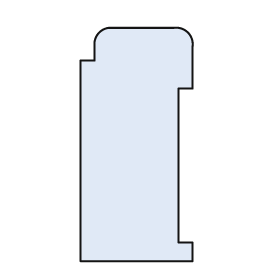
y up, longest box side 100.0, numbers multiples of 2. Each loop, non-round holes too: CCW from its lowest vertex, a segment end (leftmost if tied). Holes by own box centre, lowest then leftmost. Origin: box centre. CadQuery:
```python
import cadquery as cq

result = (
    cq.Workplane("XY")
    .moveTo(-24.0, -50.0)
    .lineTo(24.0, -50.0)
    .lineTo(24.0, -42.0)
    .lineTo(18.0, -42.0)
    .lineTo(18.0, 24.0)
    .lineTo(24.0, 24.0)
    .lineTo(24.0, 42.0)
    .threePointArc((22.0, 48.0), (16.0, 50.0))
    .lineTo(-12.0, 50.0)
    .threePointArc((-16.0, 48.0), (-18.0, 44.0))
    .lineTo(-18.0, 36.0)
    .lineTo(-24.0, 36.0)
    .close()
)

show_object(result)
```